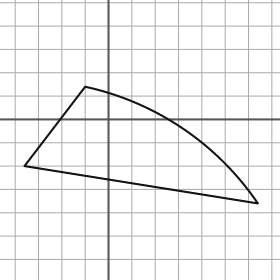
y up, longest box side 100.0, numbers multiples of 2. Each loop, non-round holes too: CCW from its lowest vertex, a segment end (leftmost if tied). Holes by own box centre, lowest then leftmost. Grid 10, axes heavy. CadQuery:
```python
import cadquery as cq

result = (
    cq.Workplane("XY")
    .moveTo(64.0, -36.0)
    .threePointArc((32.0, -4.0), (-10.0, 14.0))
    .lineTo(-36.0, -20.0)
    .close()
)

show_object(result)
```